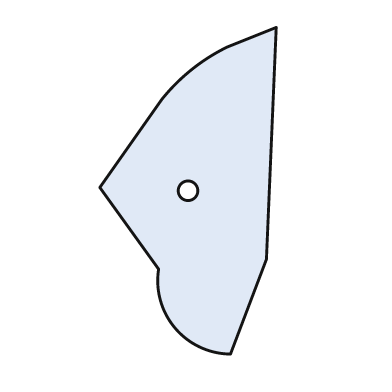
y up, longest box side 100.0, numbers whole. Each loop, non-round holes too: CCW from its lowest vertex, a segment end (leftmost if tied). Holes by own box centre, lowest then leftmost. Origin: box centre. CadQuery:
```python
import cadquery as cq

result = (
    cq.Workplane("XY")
    .moveTo(13.0, -50.0)
    .lineTo(24.0, -21.0)
    .lineTo(27.0, 50.0)
    .lineTo(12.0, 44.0)
    .threePointArc((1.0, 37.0), (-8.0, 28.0))
    .lineTo(-27.0, 1.0)
    .lineTo(-9.0, -24.0)
    .threePointArc((-4.0, -42.0), (13.0, -50.0))
    .close()
    .moveTo(0.0, 0.0)
    .circle(3.0)
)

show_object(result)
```